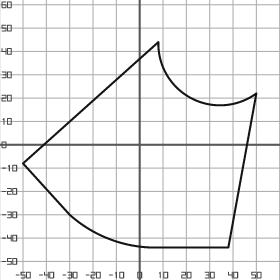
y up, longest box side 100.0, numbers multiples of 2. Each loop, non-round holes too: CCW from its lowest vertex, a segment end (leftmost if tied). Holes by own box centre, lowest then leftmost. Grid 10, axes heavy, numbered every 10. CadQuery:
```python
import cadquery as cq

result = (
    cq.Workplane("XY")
    .moveTo(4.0, -44.0)
    .lineTo(38.0, -44.0)
    .lineTo(50.0, 22.0)
    .threePointArc((22.0, 20.0), (8.0, 44.0))
    .lineTo(-50.0, -8.0)
    .lineTo(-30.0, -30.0)
    .threePointArc((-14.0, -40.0), (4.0, -44.0))
    .close()
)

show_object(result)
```